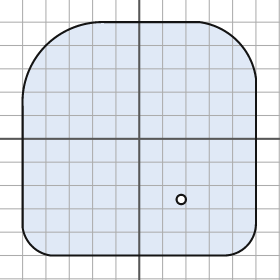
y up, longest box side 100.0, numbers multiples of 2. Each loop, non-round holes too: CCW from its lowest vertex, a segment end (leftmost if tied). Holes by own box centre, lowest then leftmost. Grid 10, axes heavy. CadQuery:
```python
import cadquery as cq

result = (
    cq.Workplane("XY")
    .moveTo(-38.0, -50.0)
    .lineTo(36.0, -50.0)
    .threePointArc((46.0, -46.0), (50.0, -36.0))
    .lineTo(50.0, 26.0)
    .threePointArc((42.0, 42.0), (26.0, 50.0))
    .lineTo(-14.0, 50.0)
    .threePointArc((-40.0, 40.0), (-50.0, 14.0))
    .lineTo(-50.0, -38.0)
    .threePointArc((-46.0, -46.0), (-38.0, -50.0))
    .close()
    .moveTo(18.0, -26.0)
    .circle(2.0)
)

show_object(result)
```